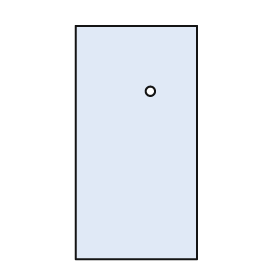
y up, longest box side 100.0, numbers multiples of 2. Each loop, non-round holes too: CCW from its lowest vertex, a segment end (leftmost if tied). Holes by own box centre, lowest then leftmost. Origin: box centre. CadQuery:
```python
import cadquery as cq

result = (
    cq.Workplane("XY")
    .moveTo(-26.0, -50.0)
    .lineTo(26.0, -50.0)
    .lineTo(26.0, 50.0)
    .lineTo(-26.0, 50.0)
    .close()
    .moveTo(6.0, 22.0)
    .circle(2.0)
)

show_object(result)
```